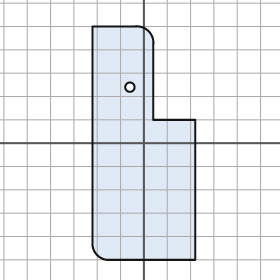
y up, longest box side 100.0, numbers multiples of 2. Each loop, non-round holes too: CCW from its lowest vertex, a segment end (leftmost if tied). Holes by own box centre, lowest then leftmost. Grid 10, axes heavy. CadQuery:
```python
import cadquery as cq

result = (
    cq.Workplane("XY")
    .moveTo(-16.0, -50.0)
    .lineTo(22.0, -50.0)
    .lineTo(22.0, 10.0)
    .lineTo(4.0, 10.0)
    .lineTo(4.0, 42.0)
    .threePointArc((2.0, 48.0), (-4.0, 50.0))
    .lineTo(-22.0, 50.0)
    .lineTo(-22.0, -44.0)
    .threePointArc((-20.0, -48.0), (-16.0, -50.0))
    .close()
    .moveTo(-6.0, 24.0)
    .circle(2.0)
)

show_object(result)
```